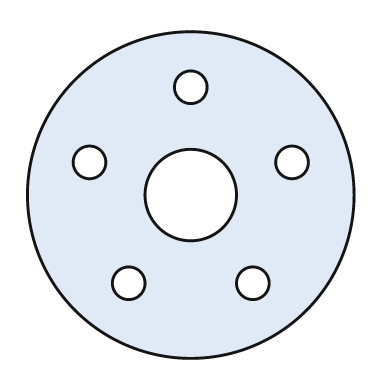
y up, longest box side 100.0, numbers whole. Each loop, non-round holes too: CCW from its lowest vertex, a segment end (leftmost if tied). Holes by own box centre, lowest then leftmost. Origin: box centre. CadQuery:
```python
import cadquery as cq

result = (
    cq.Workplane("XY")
    .moveTo(0.0, 0.0)
    .circle(50.0)
    .moveTo(-19.0, -27.0)
    .circle(5.0)
    .moveTo(19.0, -27.0)
    .circle(5.0)
    .moveTo(0.0, 0.0)
    .circle(14.0)
    .moveTo(-31.0, 10.0)
    .circle(5.0)
    .moveTo(31.0, 10.0)
    .circle(5.0)
    .moveTo(0.0, 33.0)
    .circle(5.0)
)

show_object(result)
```